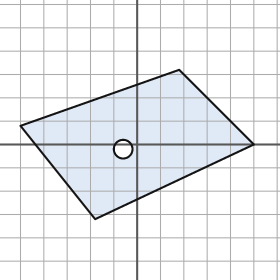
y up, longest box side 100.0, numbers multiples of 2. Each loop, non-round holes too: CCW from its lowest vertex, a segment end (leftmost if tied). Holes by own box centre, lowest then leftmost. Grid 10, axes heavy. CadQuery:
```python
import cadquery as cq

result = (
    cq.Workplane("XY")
    .moveTo(-18.0, -32.0)
    .lineTo(50.0, 0.0)
    .lineTo(18.0, 32.0)
    .lineTo(-50.0, 8.0)
    .close()
    .moveTo(-6.0, -2.0)
    .circle(4.0)
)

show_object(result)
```